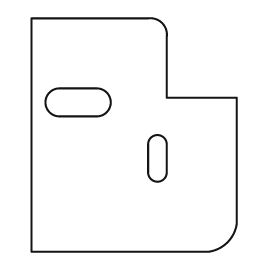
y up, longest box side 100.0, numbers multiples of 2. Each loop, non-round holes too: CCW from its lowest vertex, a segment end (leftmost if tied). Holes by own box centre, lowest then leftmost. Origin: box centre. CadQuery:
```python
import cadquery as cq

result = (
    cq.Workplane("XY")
    .moveTo(-44.0, -50.0)
    .lineTo(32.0, -50.0)
    .threePointArc((40.0, -46.0), (44.0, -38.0))
    .lineTo(44.0, 16.0)
    .lineTo(14.0, 16.0)
    .lineTo(14.0, 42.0)
    .threePointArc((12.0, 48.0), (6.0, 50.0))
    .lineTo(-44.0, 50.0)
    .close()
    .moveTo(6.0, -16.0)
    .threePointArc((10.0, -20.0), (14.0, -16.0))
    .lineTo(14.0, -4.0)
    .threePointArc((10.0, 0.0), (6.0, -4.0))
    .close()
    .moveTo(-32.0, 8.0)
    .lineTo(-16.0, 8.0)
    .threePointArc((-10.0, 14.0), (-16.0, 20.0))
    .lineTo(-32.0, 20.0)
    .threePointArc((-38.0, 14.0), (-32.0, 8.0))
    .close()
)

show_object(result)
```